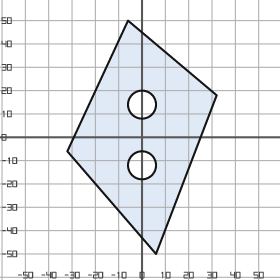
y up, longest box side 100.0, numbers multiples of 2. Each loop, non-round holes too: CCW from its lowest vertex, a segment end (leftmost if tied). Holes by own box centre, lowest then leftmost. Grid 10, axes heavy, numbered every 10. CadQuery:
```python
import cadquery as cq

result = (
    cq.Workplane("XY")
    .moveTo(6.0, -50.0)
    .lineTo(32.0, 18.0)
    .lineTo(-6.0, 50.0)
    .lineTo(-32.0, -6.0)
    .close()
    .moveTo(0.0, -12.0)
    .circle(6.0)
    .moveTo(0.0, 14.0)
    .circle(6.0)
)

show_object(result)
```